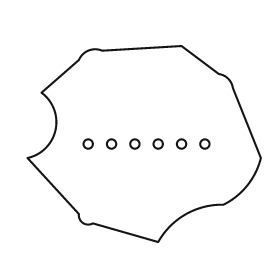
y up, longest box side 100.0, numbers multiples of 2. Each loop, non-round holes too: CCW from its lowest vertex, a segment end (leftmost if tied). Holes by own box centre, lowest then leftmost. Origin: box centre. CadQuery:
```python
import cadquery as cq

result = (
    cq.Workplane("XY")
    .moveTo(6.0, -42.0)
    .threePointArc((18.0, -30.0), (34.0, -26.0))
    .threePointArc((44.0, -18.0), (50.0, -6.0))
    .lineTo(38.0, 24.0)
    .threePointArc((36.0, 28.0), (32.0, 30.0))
    .lineTo(16.0, 42.0)
    .lineTo(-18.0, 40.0)
    .threePointArc((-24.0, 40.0), (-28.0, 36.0))
    .lineTo(-44.0, 22.0)
    .threePointArc((-38.0, 6.0), (-50.0, -6.0))
    .lineTo(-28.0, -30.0)
    .threePointArc((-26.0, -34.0), (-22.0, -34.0))
    .close()
    .moveTo(-24.0, 0.0)
    .circle(2.0)
    .moveTo(-14.0, 0.0)
    .circle(2.0)
    .moveTo(-4.0, 0.0)
    .circle(2.0)
    .moveTo(6.0, 0.0)
    .circle(2.0)
    .moveTo(16.0, 0.0)
    .circle(2.0)
    .moveTo(26.0, 0.0)
    .circle(2.0)
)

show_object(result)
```